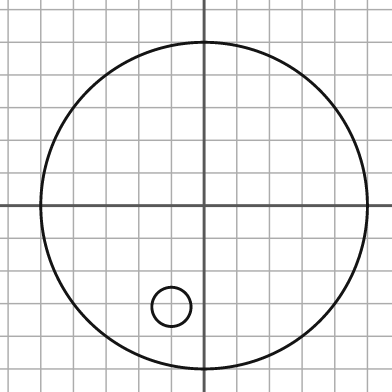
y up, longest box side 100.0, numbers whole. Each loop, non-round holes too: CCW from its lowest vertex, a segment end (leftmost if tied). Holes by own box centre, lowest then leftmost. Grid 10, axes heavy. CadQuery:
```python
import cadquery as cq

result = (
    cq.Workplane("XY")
    .moveTo(0.0, 0.0)
    .circle(50.0)
    .moveTo(-10.0, -31.0)
    .circle(6.0)
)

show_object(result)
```